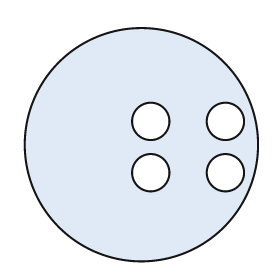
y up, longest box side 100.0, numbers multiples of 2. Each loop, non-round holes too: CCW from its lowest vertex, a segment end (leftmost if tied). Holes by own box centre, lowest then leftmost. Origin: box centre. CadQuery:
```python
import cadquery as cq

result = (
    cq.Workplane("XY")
    .moveTo(0.0, 0.0)
    .circle(50.0)
    .moveTo(4.0, -12.0)
    .circle(8.0)
    .moveTo(36.0, -12.0)
    .circle(8.0)
    .moveTo(4.0, 10.0)
    .circle(8.0)
    .moveTo(36.0, 10.0)
    .circle(8.0)
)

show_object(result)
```